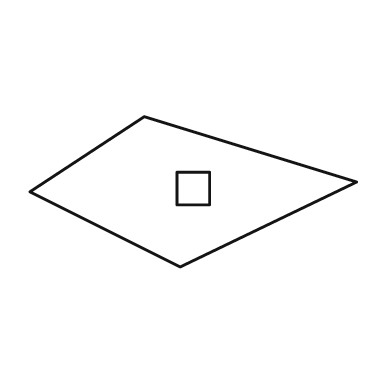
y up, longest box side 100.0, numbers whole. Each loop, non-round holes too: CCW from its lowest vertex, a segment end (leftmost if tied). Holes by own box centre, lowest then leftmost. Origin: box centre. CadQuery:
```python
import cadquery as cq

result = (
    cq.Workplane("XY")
    .moveTo(-4.0, -23.0)
    .lineTo(50.0, 3.0)
    .lineTo(-15.0, 23.0)
    .lineTo(-50.0, 0.0)
    .close()
    .moveTo(-5.0, -4.0)
    .lineTo(5.0, -4.0)
    .lineTo(5.0, 6.0)
    .lineTo(-5.0, 6.0)
    .close()
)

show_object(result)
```